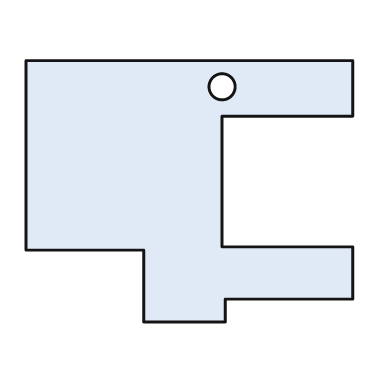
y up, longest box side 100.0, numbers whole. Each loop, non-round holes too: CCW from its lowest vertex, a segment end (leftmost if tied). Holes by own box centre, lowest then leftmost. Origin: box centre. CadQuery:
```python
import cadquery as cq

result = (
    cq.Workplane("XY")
    .moveTo(-14.0, -40.0)
    .lineTo(11.0, -40.0)
    .lineTo(11.0, -33.0)
    .lineTo(50.0, -33.0)
    .lineTo(50.0, -17.0)
    .lineTo(10.0, -17.0)
    .lineTo(10.0, 23.0)
    .lineTo(50.0, 23.0)
    .lineTo(50.0, 40.0)
    .lineTo(-50.0, 40.0)
    .lineTo(-50.0, -18.0)
    .lineTo(-14.0, -18.0)
    .close()
    .moveTo(10.0, 32.0)
    .circle(4.0)
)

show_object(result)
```